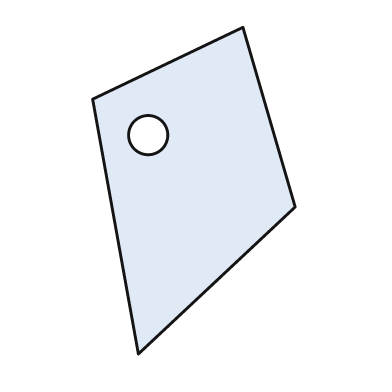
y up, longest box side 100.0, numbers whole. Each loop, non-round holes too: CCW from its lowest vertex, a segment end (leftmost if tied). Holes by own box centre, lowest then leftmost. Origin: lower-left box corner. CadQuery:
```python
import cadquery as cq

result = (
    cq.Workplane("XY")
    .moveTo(14.0, 0.0)
    .lineTo(62.0, 45.0)
    .lineTo(46.0, 100.0)
    .lineTo(0.0, 78.0)
    .close()
    .moveTo(17.0, 67.0)
    .circle(6.0)
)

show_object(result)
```